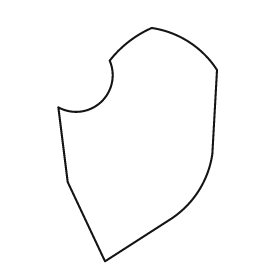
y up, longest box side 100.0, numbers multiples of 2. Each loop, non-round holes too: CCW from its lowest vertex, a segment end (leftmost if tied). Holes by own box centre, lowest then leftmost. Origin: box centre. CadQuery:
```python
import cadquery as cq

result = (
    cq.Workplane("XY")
    .moveTo(-14.0, -50.0)
    .lineTo(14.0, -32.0)
    .threePointArc((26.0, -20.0), (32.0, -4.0))
    .lineTo(34.0, 32.0)
    .threePointArc((22.0, 44.0), (6.0, 50.0))
    .threePointArc((-4.0, 44.0), (-12.0, 36.0))
    .threePointArc((-16.0, 18.0), (-34.0, 16.0))
    .lineTo(-30.0, -16.0)
    .close()
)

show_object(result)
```